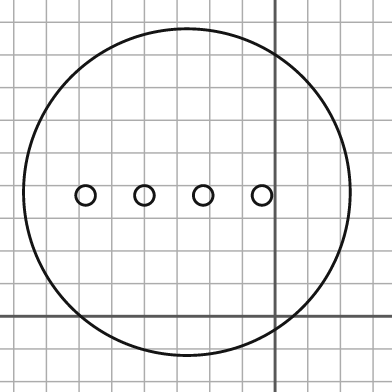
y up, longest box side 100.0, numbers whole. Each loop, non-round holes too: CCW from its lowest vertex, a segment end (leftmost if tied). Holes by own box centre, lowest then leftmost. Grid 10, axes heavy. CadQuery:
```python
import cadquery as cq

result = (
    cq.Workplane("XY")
    .moveTo(-27.0, 38.0)
    .circle(50.0)
    .moveTo(-58.0, 37.0)
    .circle(3.0)
    .moveTo(-40.0, 37.0)
    .circle(3.0)
    .moveTo(-22.0, 37.0)
    .circle(3.0)
    .moveTo(-4.0, 37.0)
    .circle(3.0)
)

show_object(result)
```